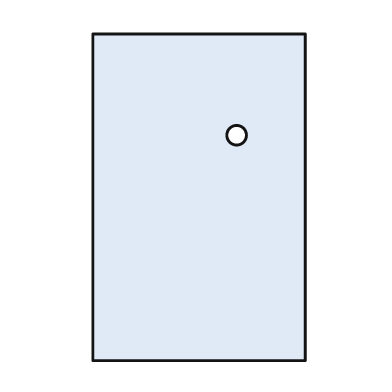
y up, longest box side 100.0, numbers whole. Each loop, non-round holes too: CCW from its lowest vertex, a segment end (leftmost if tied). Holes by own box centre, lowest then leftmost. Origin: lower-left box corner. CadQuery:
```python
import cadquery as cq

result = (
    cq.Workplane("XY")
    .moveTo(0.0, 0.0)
    .lineTo(65.0, 0.0)
    .lineTo(65.0, 100.0)
    .lineTo(0.0, 100.0)
    .close()
    .moveTo(44.0, 69.0)
    .circle(3.0)
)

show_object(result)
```